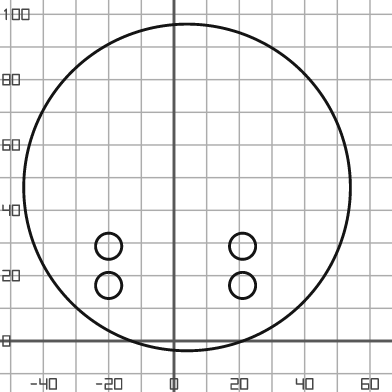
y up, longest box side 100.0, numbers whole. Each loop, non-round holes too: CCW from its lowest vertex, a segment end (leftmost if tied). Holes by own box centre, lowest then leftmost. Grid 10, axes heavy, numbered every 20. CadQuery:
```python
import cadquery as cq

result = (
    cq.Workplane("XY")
    .moveTo(4.0, 47.0)
    .circle(50.0)
    .moveTo(-20.0, 17.0)
    .circle(4.0)
    .moveTo(21.0, 17.0)
    .circle(4.0)
    .moveTo(-20.0, 29.0)
    .circle(4.0)
    .moveTo(21.0, 29.0)
    .circle(4.0)
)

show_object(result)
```